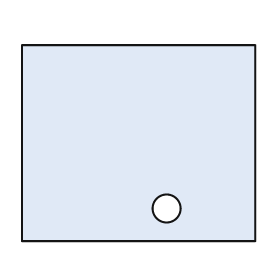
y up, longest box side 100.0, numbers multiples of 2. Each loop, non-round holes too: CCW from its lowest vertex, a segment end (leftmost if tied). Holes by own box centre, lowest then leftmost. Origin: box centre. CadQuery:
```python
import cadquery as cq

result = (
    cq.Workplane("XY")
    .moveTo(-50.0, -42.0)
    .lineTo(50.0, -42.0)
    .lineTo(50.0, 42.0)
    .lineTo(-50.0, 42.0)
    .close()
    .moveTo(12.0, -28.0)
    .circle(6.0)
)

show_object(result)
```